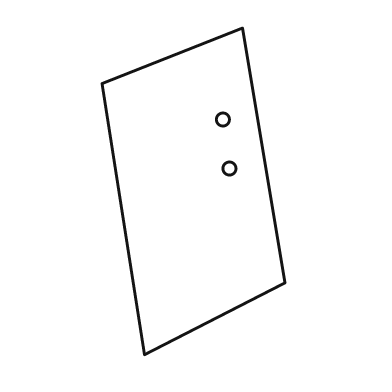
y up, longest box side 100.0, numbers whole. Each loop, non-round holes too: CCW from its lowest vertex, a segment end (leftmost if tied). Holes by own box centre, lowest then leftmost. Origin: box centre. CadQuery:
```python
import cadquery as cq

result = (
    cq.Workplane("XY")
    .moveTo(-15.0, -50.0)
    .lineTo(28.0, -28.0)
    .lineTo(15.0, 50.0)
    .lineTo(-28.0, 33.0)
    .close()
    .moveTo(11.0, 7.0)
    .circle(2.0)
    .moveTo(9.0, 22.0)
    .circle(2.0)
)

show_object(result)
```